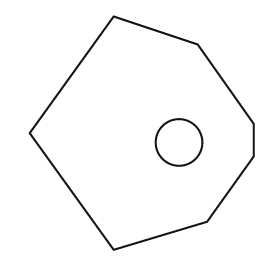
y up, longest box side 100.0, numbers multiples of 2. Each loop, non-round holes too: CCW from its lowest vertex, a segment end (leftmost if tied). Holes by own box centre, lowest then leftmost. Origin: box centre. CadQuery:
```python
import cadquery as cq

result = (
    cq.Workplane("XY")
    .moveTo(-12.0, -50.0)
    .lineTo(28.0, -38.0)
    .lineTo(48.0, -10.0)
    .lineTo(48.0, 4.0)
    .lineTo(24.0, 38.0)
    .lineTo(-12.0, 50.0)
    .lineTo(-48.0, 0.0)
    .close()
    .moveTo(16.0, -4.0)
    .circle(10.0)
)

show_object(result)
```